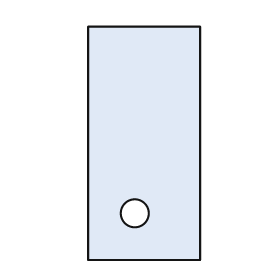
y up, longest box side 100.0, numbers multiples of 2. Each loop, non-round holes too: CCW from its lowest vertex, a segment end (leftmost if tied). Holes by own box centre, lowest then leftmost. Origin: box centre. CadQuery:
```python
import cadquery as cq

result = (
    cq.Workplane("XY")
    .moveTo(-24.0, -50.0)
    .lineTo(24.0, -50.0)
    .lineTo(24.0, 50.0)
    .lineTo(-24.0, 50.0)
    .close()
    .moveTo(-4.0, -30.0)
    .circle(6.0)
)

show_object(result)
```